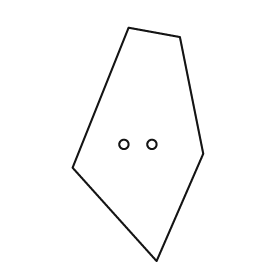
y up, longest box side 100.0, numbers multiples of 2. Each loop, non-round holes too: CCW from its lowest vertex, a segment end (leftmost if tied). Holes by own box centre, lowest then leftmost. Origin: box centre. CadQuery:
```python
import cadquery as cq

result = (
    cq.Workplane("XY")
    .moveTo(8.0, -50.0)
    .lineTo(28.0, -4.0)
    .lineTo(18.0, 46.0)
    .lineTo(-4.0, 50.0)
    .lineTo(-28.0, -10.0)
    .close()
    .moveTo(-6.0, 0.0)
    .circle(2.0)
    .moveTo(6.0, 0.0)
    .circle(2.0)
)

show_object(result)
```